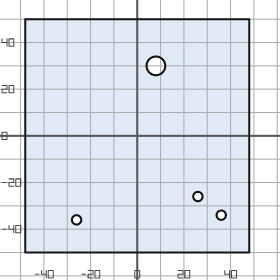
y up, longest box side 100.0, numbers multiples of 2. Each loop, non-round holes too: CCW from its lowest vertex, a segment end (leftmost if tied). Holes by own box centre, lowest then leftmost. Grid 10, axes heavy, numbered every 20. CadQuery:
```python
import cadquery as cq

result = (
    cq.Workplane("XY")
    .moveTo(-48.0, -50.0)
    .lineTo(48.0, -50.0)
    .lineTo(48.0, 50.0)
    .lineTo(-48.0, 50.0)
    .close()
    .moveTo(-26.0, -36.0)
    .circle(2.0)
    .moveTo(36.0, -34.0)
    .circle(2.0)
    .moveTo(26.0, -26.0)
    .circle(2.0)
    .moveTo(8.0, 30.0)
    .circle(4.0)
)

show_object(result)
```